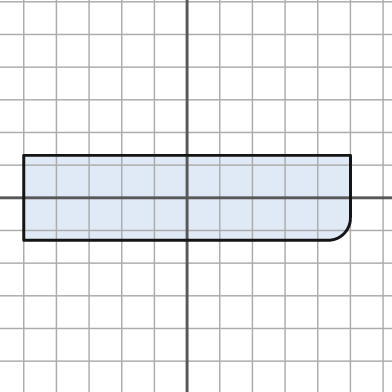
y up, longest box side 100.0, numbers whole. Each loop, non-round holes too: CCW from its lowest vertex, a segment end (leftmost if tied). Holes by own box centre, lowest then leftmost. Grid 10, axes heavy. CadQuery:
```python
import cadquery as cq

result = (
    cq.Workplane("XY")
    .moveTo(-50.0, -13.0)
    .lineTo(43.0, -13.0)
    .threePointArc((48.0, -11.0), (50.0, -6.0))
    .lineTo(50.0, 13.0)
    .lineTo(-50.0, 13.0)
    .close()
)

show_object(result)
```